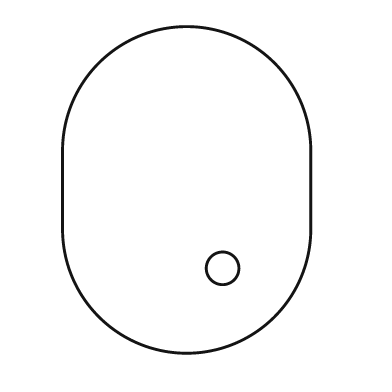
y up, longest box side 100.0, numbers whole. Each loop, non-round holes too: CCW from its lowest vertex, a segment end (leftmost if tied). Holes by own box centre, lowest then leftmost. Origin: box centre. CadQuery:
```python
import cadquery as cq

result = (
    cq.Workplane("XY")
    .moveTo(-38.0, -12.0)
    .threePointArc((0.0, -50.0), (38.0, -12.0))
    .lineTo(38.0, 12.0)
    .threePointArc((0.0, 50.0), (-38.0, 12.0))
    .close()
    .moveTo(11.0, -24.0)
    .circle(5.0)
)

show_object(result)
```